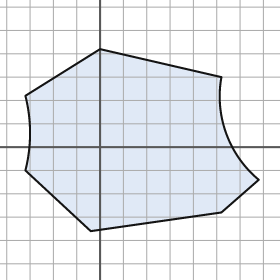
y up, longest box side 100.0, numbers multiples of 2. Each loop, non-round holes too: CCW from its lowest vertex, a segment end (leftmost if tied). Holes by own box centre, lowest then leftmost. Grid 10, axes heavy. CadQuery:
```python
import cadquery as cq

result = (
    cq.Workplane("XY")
    .moveTo(-4.0, -36.0)
    .lineTo(52.0, -28.0)
    .lineTo(68.0, -14.0)
    .threePointArc((54.0, 6.0), (52.0, 30.0))
    .lineTo(0.0, 42.0)
    .lineTo(-32.0, 22.0)
    .threePointArc((-30.0, 6.0), (-32.0, -10.0))
    .close()
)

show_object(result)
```